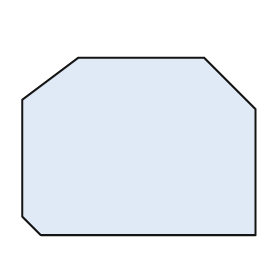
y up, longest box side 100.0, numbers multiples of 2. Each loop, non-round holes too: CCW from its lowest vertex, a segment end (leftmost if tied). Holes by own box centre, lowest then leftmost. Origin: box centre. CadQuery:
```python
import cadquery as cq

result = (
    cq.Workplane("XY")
    .moveTo(-42.0, -38.0)
    .lineTo(50.0, -38.0)
    .lineTo(50.0, 16.0)
    .lineTo(28.0, 38.0)
    .lineTo(-26.0, 38.0)
    .lineTo(-50.0, 20.0)
    .lineTo(-50.0, -30.0)
    .close()
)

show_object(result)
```